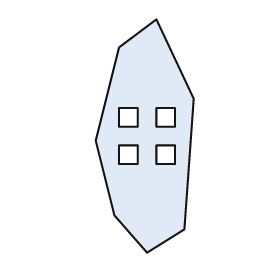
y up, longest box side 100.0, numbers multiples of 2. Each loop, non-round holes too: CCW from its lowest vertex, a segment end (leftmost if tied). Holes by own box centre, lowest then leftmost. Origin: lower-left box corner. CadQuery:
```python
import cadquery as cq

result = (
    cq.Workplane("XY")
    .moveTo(22.0, 0.0)
    .lineTo(38.0, 10.0)
    .lineTo(42.0, 66.0)
    .lineTo(26.0, 100.0)
    .lineTo(10.0, 88.0)
    .lineTo(0.0, 48.0)
    .lineTo(8.0, 16.0)
    .close()
    .moveTo(10.0, 38.0)
    .lineTo(18.0, 38.0)
    .lineTo(18.0, 46.0)
    .lineTo(10.0, 46.0)
    .close()
    .moveTo(26.0, 38.0)
    .lineTo(34.0, 38.0)
    .lineTo(34.0, 46.0)
    .lineTo(26.0, 46.0)
    .close()
    .moveTo(10.0, 54.0)
    .lineTo(18.0, 54.0)
    .lineTo(18.0, 62.0)
    .lineTo(10.0, 62.0)
    .close()
    .moveTo(26.0, 54.0)
    .lineTo(34.0, 54.0)
    .lineTo(34.0, 62.0)
    .lineTo(26.0, 62.0)
    .close()
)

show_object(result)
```